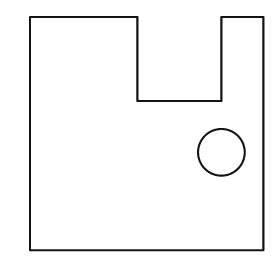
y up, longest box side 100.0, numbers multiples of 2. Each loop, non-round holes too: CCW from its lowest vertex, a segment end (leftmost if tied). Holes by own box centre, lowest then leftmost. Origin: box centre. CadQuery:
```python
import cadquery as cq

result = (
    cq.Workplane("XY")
    .moveTo(-50.0, -50.0)
    .lineTo(50.0, -50.0)
    .lineTo(50.0, 50.0)
    .lineTo(32.0, 50.0)
    .lineTo(32.0, 14.0)
    .lineTo(-4.0, 14.0)
    .lineTo(-4.0, 50.0)
    .lineTo(-50.0, 50.0)
    .close()
    .moveTo(32.0, -8.0)
    .circle(10.0)
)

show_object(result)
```